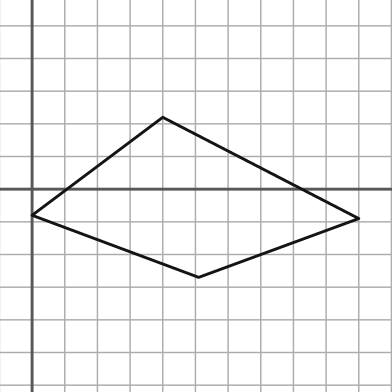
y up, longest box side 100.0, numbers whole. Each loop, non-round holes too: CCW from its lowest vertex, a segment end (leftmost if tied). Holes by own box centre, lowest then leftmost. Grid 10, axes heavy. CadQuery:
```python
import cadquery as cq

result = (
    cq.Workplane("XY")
    .moveTo(51.0, -27.0)
    .lineTo(100.0, -9.0)
    .lineTo(40.0, 22.0)
    .lineTo(0.0, -8.0)
    .close()
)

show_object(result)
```